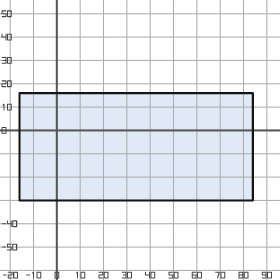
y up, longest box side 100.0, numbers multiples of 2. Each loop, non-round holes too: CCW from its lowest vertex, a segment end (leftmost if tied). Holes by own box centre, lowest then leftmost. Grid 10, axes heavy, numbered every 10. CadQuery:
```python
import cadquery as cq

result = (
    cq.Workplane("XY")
    .moveTo(-16.0, -30.0)
    .lineTo(84.0, -30.0)
    .lineTo(84.0, 16.0)
    .lineTo(-16.0, 16.0)
    .close()
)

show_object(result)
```